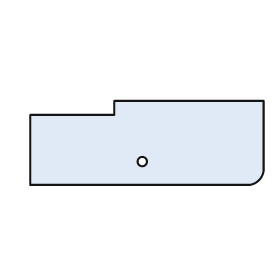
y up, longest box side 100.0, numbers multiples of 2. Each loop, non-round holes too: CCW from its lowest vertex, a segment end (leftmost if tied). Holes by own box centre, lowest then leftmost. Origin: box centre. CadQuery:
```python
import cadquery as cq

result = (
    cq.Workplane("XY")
    .moveTo(-50.0, -18.0)
    .lineTo(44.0, -18.0)
    .threePointArc((48.0, -16.0), (50.0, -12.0))
    .lineTo(50.0, 18.0)
    .lineTo(-14.0, 18.0)
    .lineTo(-14.0, 12.0)
    .lineTo(-50.0, 12.0)
    .close()
    .moveTo(-2.0, -8.0)
    .circle(2.0)
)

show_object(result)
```